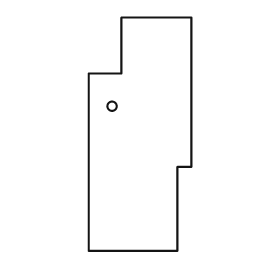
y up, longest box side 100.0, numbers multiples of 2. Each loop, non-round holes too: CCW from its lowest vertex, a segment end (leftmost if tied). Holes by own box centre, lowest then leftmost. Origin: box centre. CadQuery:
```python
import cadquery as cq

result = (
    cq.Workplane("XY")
    .moveTo(-22.0, -50.0)
    .lineTo(16.0, -50.0)
    .lineTo(16.0, -14.0)
    .lineTo(22.0, -14.0)
    .lineTo(22.0, 50.0)
    .lineTo(-8.0, 50.0)
    .lineTo(-8.0, 26.0)
    .lineTo(-22.0, 26.0)
    .close()
    .moveTo(-12.0, 12.0)
    .circle(2.0)
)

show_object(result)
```